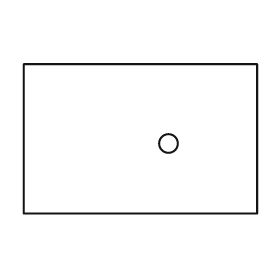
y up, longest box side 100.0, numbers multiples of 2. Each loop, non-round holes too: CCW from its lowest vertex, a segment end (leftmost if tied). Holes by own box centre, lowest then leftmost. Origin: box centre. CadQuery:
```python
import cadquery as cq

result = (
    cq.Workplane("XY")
    .moveTo(-50.0, -32.0)
    .lineTo(50.0, -32.0)
    .lineTo(50.0, 32.0)
    .lineTo(-50.0, 32.0)
    .close()
    .moveTo(12.0, -2.0)
    .circle(4.0)
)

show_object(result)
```